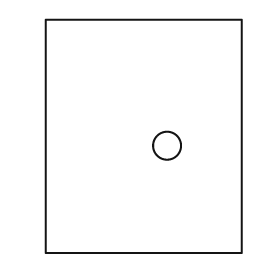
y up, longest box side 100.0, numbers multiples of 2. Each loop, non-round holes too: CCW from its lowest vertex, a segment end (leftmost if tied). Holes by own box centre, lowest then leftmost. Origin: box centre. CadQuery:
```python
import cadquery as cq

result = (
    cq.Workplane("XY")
    .moveTo(-42.0, -50.0)
    .lineTo(42.0, -50.0)
    .lineTo(42.0, 50.0)
    .lineTo(-42.0, 50.0)
    .close()
    .moveTo(10.0, -4.0)
    .circle(6.0)
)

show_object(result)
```